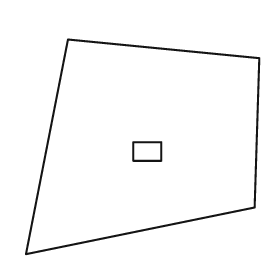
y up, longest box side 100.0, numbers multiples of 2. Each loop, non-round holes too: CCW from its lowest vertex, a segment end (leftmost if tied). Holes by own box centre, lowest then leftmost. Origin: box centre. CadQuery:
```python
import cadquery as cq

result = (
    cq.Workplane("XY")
    .moveTo(-50.0, -46.0)
    .lineTo(48.0, -26.0)
    .lineTo(50.0, 38.0)
    .lineTo(-32.0, 46.0)
    .close()
    .moveTo(-4.0, -6.0)
    .lineTo(8.0, -6.0)
    .lineTo(8.0, 2.0)
    .lineTo(-4.0, 2.0)
    .close()
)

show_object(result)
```